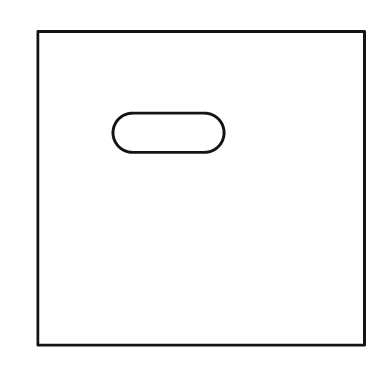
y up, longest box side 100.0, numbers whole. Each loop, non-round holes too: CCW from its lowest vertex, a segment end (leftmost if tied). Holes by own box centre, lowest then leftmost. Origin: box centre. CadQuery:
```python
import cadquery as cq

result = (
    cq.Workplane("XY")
    .moveTo(-50.0, -48.0)
    .lineTo(50.0, -48.0)
    .lineTo(50.0, 48.0)
    .lineTo(-50.0, 48.0)
    .close()
    .moveTo(-21.0, 11.0)
    .lineTo(1.0, 11.0)
    .threePointArc((7.0, 17.0), (1.0, 23.0))
    .lineTo(-21.0, 23.0)
    .threePointArc((-27.0, 17.0), (-21.0, 11.0))
    .close()
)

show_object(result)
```